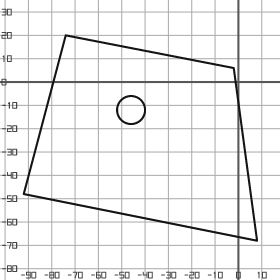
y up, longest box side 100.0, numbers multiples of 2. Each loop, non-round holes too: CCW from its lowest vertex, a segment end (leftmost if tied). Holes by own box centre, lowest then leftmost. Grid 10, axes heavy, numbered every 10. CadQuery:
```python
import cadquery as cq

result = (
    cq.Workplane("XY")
    .moveTo(8.0, -68.0)
    .lineTo(-2.0, 6.0)
    .lineTo(-74.0, 20.0)
    .lineTo(-92.0, -48.0)
    .close()
    .moveTo(-46.0, -12.0)
    .circle(6.0)
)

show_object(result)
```